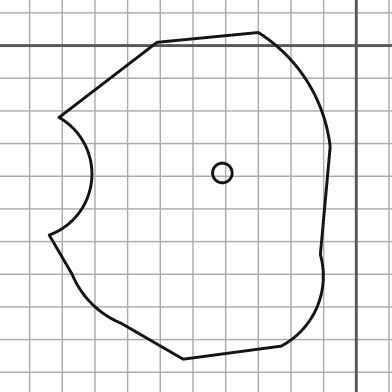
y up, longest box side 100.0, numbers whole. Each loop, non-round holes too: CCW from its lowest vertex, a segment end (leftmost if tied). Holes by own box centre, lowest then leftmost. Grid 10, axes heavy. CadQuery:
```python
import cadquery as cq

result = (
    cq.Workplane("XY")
    .moveTo(-53.0, -96.0)
    .lineTo(-23.0, -92.0)
    .threePointArc((-12.0, -80.0), (-11.0, -64.0))
    .lineTo(-8.0, -31.0)
    .threePointArc((-15.0, -11.0), (-30.0, 4.0))
    .lineTo(-61.0, 1.0)
    .lineTo(-91.0, -22.0)
    .threePointArc((-81.0, -41.0), (-94.0, -58.0))
    .lineTo(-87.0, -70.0)
    .threePointArc((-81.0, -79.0), (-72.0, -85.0))
    .close()
    .moveTo(-41.0, -39.0)
    .circle(3.0)
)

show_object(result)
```